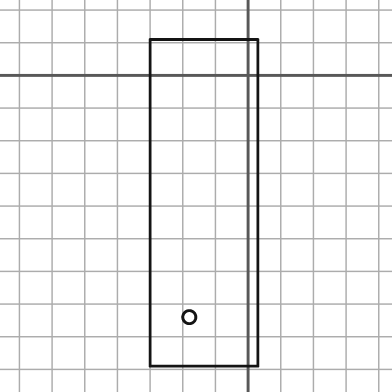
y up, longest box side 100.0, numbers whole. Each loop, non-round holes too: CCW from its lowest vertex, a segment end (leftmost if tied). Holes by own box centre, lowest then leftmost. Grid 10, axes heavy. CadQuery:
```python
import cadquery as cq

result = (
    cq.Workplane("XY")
    .moveTo(-30.0, -89.0)
    .lineTo(3.0, -89.0)
    .lineTo(3.0, 11.0)
    .lineTo(-30.0, 11.0)
    .close()
    .moveTo(-18.0, -74.0)
    .circle(2.0)
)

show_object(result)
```